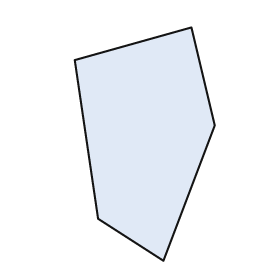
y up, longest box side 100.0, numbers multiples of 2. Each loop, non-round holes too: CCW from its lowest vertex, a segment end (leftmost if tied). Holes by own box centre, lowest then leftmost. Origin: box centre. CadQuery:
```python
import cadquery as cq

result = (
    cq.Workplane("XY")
    .moveTo(8.0, -50.0)
    .lineTo(30.0, 8.0)
    .lineTo(20.0, 50.0)
    .lineTo(-30.0, 36.0)
    .lineTo(-20.0, -32.0)
    .close()
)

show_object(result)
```